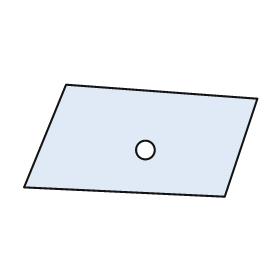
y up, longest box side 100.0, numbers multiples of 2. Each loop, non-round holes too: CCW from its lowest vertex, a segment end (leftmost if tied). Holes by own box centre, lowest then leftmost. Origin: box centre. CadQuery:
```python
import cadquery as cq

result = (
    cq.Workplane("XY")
    .moveTo(36.0, -24.0)
    .lineTo(50.0, 18.0)
    .lineTo(-32.0, 24.0)
    .lineTo(-50.0, -20.0)
    .close()
    .moveTo(2.0, -4.0)
    .circle(4.0)
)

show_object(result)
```